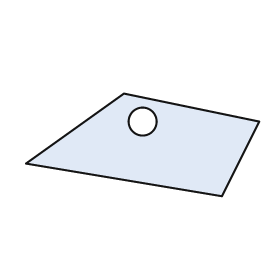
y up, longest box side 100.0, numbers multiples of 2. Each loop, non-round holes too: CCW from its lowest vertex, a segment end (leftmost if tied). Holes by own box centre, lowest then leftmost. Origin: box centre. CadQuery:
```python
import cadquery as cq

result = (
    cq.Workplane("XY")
    .moveTo(34.0, -22.0)
    .lineTo(50.0, 10.0)
    .lineTo(-8.0, 22.0)
    .lineTo(-50.0, -8.0)
    .close()
    .moveTo(0.0, 10.0)
    .circle(6.0)
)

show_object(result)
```